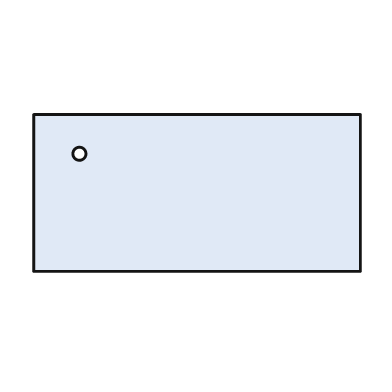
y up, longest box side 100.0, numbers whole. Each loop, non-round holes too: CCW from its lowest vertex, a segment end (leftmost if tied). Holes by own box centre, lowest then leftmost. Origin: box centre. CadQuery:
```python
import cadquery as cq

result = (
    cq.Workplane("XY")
    .moveTo(-50.0, -24.0)
    .lineTo(50.0, -24.0)
    .lineTo(50.0, 24.0)
    .lineTo(-50.0, 24.0)
    .close()
    .moveTo(-36.0, 12.0)
    .circle(2.0)
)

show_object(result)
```